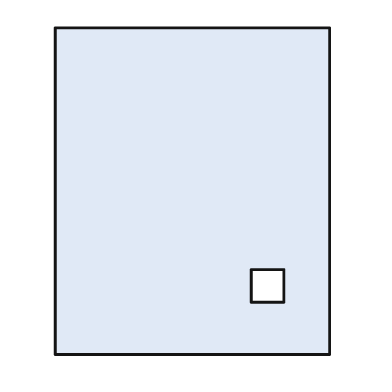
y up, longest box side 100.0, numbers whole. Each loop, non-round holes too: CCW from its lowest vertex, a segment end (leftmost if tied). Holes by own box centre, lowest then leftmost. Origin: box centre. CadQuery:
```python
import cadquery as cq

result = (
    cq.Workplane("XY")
    .moveTo(-42.0, -50.0)
    .lineTo(42.0, -50.0)
    .lineTo(42.0, 50.0)
    .lineTo(-42.0, 50.0)
    .close()
    .moveTo(18.0, -34.0)
    .lineTo(28.0, -34.0)
    .lineTo(28.0, -24.0)
    .lineTo(18.0, -24.0)
    .close()
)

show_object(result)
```